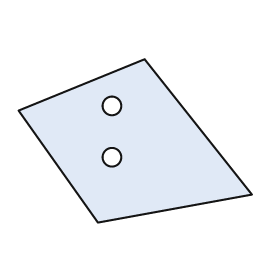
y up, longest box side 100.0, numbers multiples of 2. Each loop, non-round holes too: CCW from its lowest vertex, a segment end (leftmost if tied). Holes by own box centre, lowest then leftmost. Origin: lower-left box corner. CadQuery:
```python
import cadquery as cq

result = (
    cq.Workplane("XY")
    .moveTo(34.0, 0.0)
    .lineTo(100.0, 12.0)
    .lineTo(54.0, 70.0)
    .lineTo(0.0, 48.0)
    .close()
    .moveTo(40.0, 28.0)
    .circle(4.0)
    .moveTo(40.0, 50.0)
    .circle(4.0)
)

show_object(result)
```